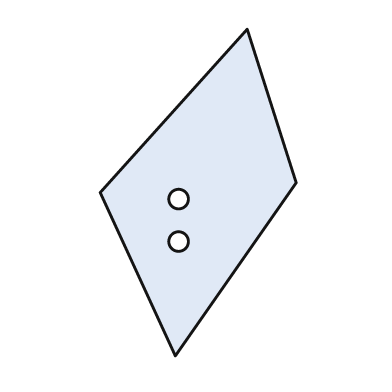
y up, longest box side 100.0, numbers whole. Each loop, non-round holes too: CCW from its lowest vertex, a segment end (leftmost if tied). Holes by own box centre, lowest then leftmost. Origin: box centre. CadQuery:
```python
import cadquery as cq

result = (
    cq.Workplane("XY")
    .moveTo(-7.0, -50.0)
    .lineTo(30.0, 3.0)
    .lineTo(15.0, 50.0)
    .lineTo(-30.0, 0.0)
    .close()
    .moveTo(-6.0, -15.0)
    .circle(3.0)
    .moveTo(-6.0, -2.0)
    .circle(3.0)
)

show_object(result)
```